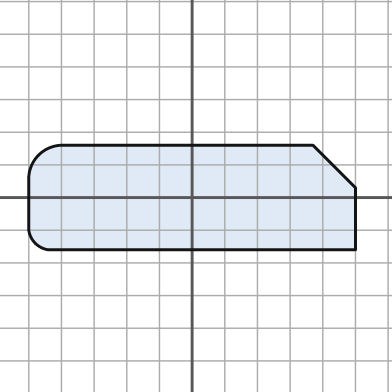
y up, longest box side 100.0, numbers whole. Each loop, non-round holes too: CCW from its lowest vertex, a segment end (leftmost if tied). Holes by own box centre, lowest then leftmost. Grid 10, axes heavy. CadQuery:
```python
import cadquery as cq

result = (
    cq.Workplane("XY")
    .moveTo(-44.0, -16.0)
    .lineTo(50.0, -16.0)
    .lineTo(50.0, 3.0)
    .lineTo(37.0, 16.0)
    .lineTo(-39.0, 16.0)
    .threePointArc((-47.0, 13.0), (-50.0, 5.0))
    .lineTo(-50.0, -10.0)
    .threePointArc((-48.0, -14.0), (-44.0, -16.0))
    .close()
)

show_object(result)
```